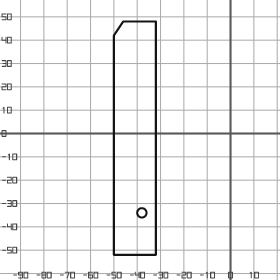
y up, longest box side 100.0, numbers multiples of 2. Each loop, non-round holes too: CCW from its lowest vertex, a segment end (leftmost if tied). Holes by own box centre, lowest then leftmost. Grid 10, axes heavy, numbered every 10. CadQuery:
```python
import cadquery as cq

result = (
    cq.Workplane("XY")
    .moveTo(-50.0, -52.0)
    .lineTo(-32.0, -52.0)
    .lineTo(-32.0, 48.0)
    .lineTo(-46.0, 48.0)
    .lineTo(-50.0, 42.0)
    .close()
    .moveTo(-38.0, -34.0)
    .circle(2.0)
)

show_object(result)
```